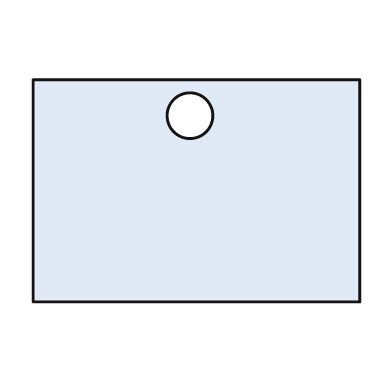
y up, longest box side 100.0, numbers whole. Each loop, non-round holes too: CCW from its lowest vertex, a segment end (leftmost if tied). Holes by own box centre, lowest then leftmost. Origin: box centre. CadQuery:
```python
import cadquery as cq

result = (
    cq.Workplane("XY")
    .moveTo(-50.0, -34.0)
    .lineTo(50.0, -34.0)
    .lineTo(50.0, 34.0)
    .lineTo(-50.0, 34.0)
    .close()
    .moveTo(-2.0, 23.0)
    .circle(7.0)
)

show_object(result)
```